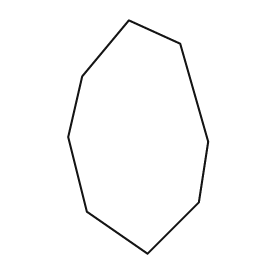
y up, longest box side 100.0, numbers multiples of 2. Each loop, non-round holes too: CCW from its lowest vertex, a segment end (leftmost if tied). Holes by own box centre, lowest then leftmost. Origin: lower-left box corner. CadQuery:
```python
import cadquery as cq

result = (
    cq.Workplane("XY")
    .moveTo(34.0, 0.0)
    .lineTo(56.0, 22.0)
    .lineTo(60.0, 48.0)
    .lineTo(48.0, 90.0)
    .lineTo(26.0, 100.0)
    .lineTo(6.0, 76.0)
    .lineTo(0.0, 50.0)
    .lineTo(8.0, 18.0)
    .close()
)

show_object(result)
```